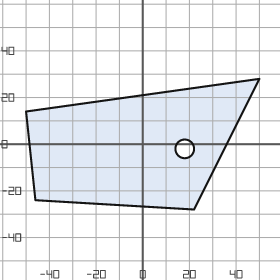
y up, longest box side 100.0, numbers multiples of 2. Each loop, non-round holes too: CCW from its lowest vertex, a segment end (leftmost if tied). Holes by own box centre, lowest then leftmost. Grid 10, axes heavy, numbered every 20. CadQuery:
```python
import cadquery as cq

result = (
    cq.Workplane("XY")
    .moveTo(22.0, -28.0)
    .lineTo(50.0, 28.0)
    .lineTo(-50.0, 14.0)
    .lineTo(-46.0, -24.0)
    .close()
    .moveTo(18.0, -2.0)
    .circle(4.0)
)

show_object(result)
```